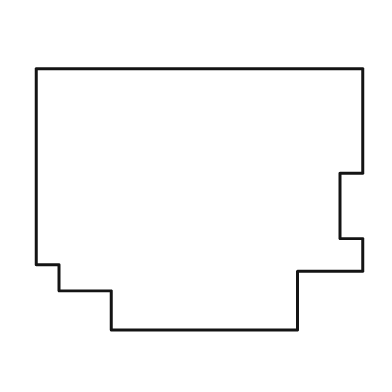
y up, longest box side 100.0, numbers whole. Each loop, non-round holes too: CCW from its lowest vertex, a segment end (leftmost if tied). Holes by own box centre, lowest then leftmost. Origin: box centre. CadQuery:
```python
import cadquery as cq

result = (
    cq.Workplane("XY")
    .moveTo(-27.0, -40.0)
    .lineTo(30.0, -40.0)
    .lineTo(30.0, -22.0)
    .lineTo(50.0, -22.0)
    .lineTo(50.0, -12.0)
    .lineTo(43.0, -12.0)
    .lineTo(43.0, 8.0)
    .lineTo(50.0, 8.0)
    .lineTo(50.0, 40.0)
    .lineTo(-50.0, 40.0)
    .lineTo(-50.0, -20.0)
    .lineTo(-43.0, -20.0)
    .lineTo(-43.0, -28.0)
    .lineTo(-27.0, -28.0)
    .close()
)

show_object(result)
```